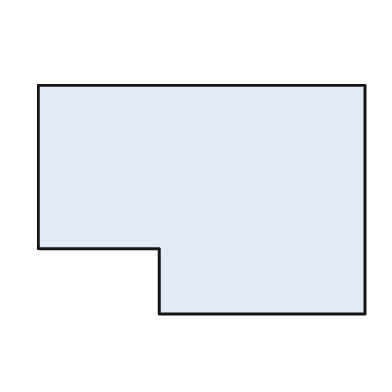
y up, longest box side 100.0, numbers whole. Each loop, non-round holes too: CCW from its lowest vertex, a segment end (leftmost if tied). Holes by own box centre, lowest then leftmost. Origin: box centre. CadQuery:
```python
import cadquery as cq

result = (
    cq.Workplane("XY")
    .moveTo(-13.0, -35.0)
    .lineTo(50.0, -35.0)
    .lineTo(50.0, 35.0)
    .lineTo(-50.0, 35.0)
    .lineTo(-50.0, -15.0)
    .lineTo(-13.0, -15.0)
    .close()
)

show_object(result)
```